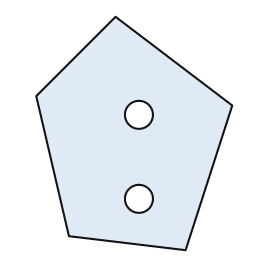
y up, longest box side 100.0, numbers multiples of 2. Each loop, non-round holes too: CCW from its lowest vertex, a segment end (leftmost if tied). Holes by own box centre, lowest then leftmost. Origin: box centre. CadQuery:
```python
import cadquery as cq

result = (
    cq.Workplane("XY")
    .moveTo(22.0, -50.0)
    .lineTo(42.0, 12.0)
    .lineTo(-8.0, 50.0)
    .lineTo(-42.0, 16.0)
    .lineTo(-28.0, -44.0)
    .close()
    .moveTo(2.0, -28.0)
    .circle(6.0)
    .moveTo(2.0, 8.0)
    .circle(6.0)
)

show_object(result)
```